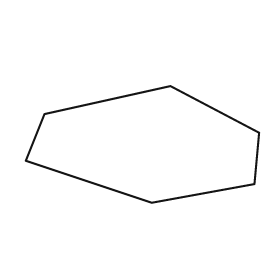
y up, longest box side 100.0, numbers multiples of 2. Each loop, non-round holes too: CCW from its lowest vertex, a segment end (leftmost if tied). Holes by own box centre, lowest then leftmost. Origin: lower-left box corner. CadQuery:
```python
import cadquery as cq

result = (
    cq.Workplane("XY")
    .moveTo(54.0, 0.0)
    .lineTo(98.0, 8.0)
    .lineTo(100.0, 30.0)
    .lineTo(62.0, 50.0)
    .lineTo(8.0, 38.0)
    .lineTo(0.0, 18.0)
    .close()
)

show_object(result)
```